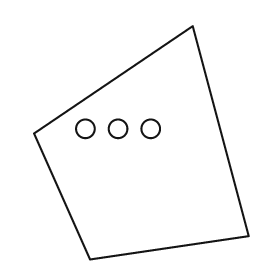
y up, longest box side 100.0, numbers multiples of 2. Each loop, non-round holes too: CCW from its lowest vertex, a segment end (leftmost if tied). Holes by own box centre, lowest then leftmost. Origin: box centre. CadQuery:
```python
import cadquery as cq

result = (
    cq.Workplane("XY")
    .moveTo(-22.0, -50.0)
    .lineTo(46.0, -40.0)
    .lineTo(22.0, 50.0)
    .lineTo(-46.0, 4.0)
    .close()
    .moveTo(-24.0, 6.0)
    .circle(4.0)
    .moveTo(-10.0, 6.0)
    .circle(4.0)
    .moveTo(4.0, 6.0)
    .circle(4.0)
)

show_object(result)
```